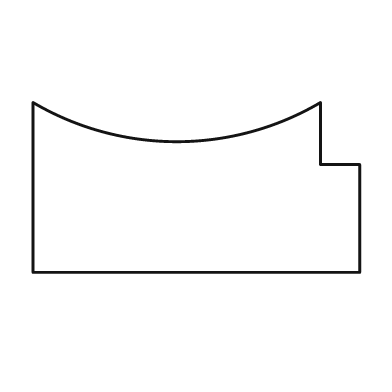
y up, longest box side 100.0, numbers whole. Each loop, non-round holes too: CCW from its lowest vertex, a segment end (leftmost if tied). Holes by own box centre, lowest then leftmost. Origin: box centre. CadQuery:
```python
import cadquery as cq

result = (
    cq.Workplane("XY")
    .moveTo(-50.0, -26.0)
    .lineTo(50.0, -26.0)
    .lineTo(50.0, 7.0)
    .lineTo(38.0, 7.0)
    .lineTo(38.0, 26.0)
    .threePointArc((-6.0, 14.0), (-50.0, 26.0))
    .close()
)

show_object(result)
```